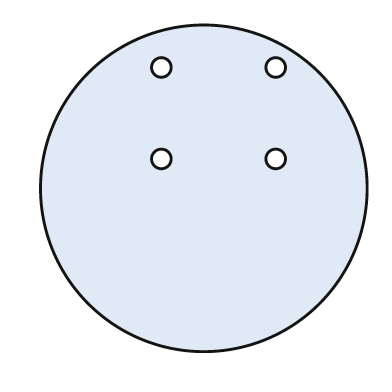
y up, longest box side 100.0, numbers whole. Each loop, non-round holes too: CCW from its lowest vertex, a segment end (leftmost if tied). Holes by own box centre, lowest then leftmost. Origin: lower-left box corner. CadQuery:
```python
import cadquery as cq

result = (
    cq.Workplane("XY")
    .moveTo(50.0, 50.0)
    .circle(50.0)
    .moveTo(37.0, 59.0)
    .circle(3.0)
    .moveTo(72.0, 59.0)
    .circle(3.0)
    .moveTo(37.0, 87.0)
    .circle(3.0)
    .moveTo(72.0, 87.0)
    .circle(3.0)
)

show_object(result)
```